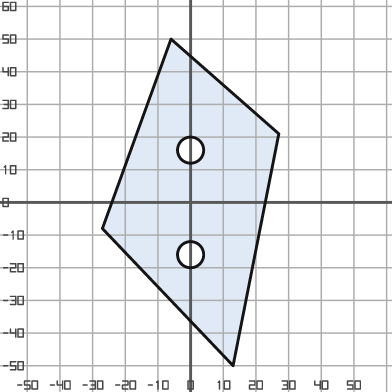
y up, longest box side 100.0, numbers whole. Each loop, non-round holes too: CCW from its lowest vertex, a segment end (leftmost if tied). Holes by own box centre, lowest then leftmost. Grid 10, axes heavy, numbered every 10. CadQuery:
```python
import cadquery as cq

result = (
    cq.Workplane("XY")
    .moveTo(13.0, -50.0)
    .lineTo(27.0, 21.0)
    .lineTo(-6.0, 50.0)
    .lineTo(-27.0, -8.0)
    .close()
    .moveTo(0.0, -16.0)
    .circle(4.0)
    .moveTo(0.0, 16.0)
    .circle(4.0)
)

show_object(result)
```